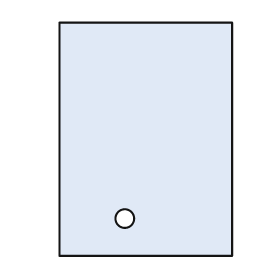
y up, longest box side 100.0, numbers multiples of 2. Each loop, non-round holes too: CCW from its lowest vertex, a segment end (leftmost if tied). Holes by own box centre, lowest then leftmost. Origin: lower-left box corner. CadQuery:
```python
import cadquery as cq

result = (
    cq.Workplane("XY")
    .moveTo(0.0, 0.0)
    .lineTo(74.0, 0.0)
    .lineTo(74.0, 100.0)
    .lineTo(0.0, 100.0)
    .close()
    .moveTo(28.0, 16.0)
    .circle(4.0)
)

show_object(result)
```